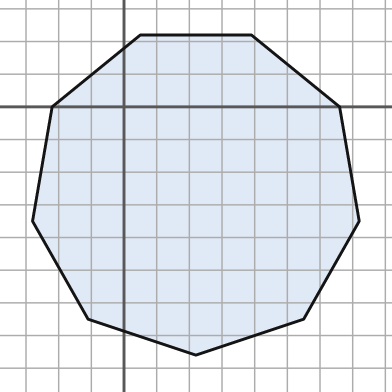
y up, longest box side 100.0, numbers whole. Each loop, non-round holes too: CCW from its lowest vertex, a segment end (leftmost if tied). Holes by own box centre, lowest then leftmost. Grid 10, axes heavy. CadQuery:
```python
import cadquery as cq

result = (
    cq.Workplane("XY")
    .moveTo(22.0, -76.0)
    .lineTo(55.0, -65.0)
    .lineTo(72.0, -35.0)
    .lineTo(66.0, 0.0)
    .lineTo(39.0, 22.0)
    .lineTo(5.0, 22.0)
    .lineTo(-22.0, 0.0)
    .lineTo(-28.0, -35.0)
    .lineTo(-11.0, -65.0)
    .close()
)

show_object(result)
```